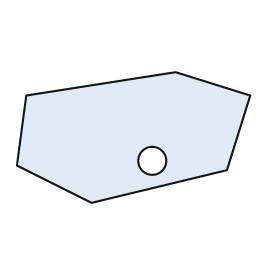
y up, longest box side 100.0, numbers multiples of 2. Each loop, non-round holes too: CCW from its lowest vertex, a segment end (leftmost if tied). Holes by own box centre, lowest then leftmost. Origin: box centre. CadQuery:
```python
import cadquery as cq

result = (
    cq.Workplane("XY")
    .moveTo(-18.0, -28.0)
    .lineTo(40.0, -14.0)
    .lineTo(50.0, 18.0)
    .lineTo(18.0, 28.0)
    .lineTo(-46.0, 18.0)
    .lineTo(-50.0, -12.0)
    .close()
    .moveTo(8.0, -10.0)
    .circle(6.0)
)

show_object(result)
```